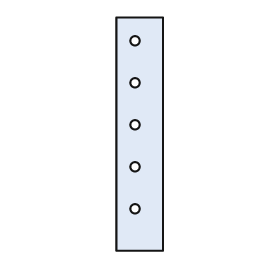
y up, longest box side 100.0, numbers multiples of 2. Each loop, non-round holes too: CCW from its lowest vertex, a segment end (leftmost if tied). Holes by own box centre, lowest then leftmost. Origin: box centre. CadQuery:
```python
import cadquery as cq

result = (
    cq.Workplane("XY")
    .moveTo(-10.0, -50.0)
    .lineTo(10.0, -50.0)
    .lineTo(10.0, 50.0)
    .lineTo(-10.0, 50.0)
    .close()
    .moveTo(-2.0, -32.0)
    .circle(2.0)
    .moveTo(-2.0, -14.0)
    .circle(2.0)
    .moveTo(-2.0, 4.0)
    .circle(2.0)
    .moveTo(-2.0, 22.0)
    .circle(2.0)
    .moveTo(-2.0, 40.0)
    .circle(2.0)
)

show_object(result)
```